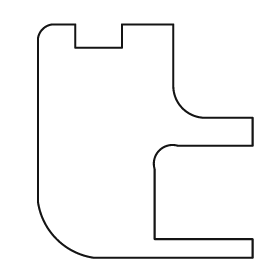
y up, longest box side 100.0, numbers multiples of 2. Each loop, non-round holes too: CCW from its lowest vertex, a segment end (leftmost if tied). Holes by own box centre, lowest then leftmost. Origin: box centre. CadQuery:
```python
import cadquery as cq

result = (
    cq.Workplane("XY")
    .moveTo(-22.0, -50.0)
    .lineTo(46.0, -50.0)
    .lineTo(46.0, -42.0)
    .lineTo(4.0, -42.0)
    .lineTo(4.0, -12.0)
    .threePointArc((6.0, -4.0), (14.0, -2.0))
    .lineTo(46.0, -2.0)
    .lineTo(46.0, 10.0)
    .lineTo(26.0, 10.0)
    .threePointArc((16.0, 14.0), (12.0, 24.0))
    .lineTo(12.0, 50.0)
    .lineTo(-10.0, 50.0)
    .lineTo(-10.0, 40.0)
    .lineTo(-30.0, 40.0)
    .lineTo(-30.0, 50.0)
    .lineTo(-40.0, 50.0)
    .threePointArc((-44.0, 48.0), (-46.0, 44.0))
    .lineTo(-46.0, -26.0)
    .threePointArc((-38.0, -42.0), (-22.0, -50.0))
    .close()
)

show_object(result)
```